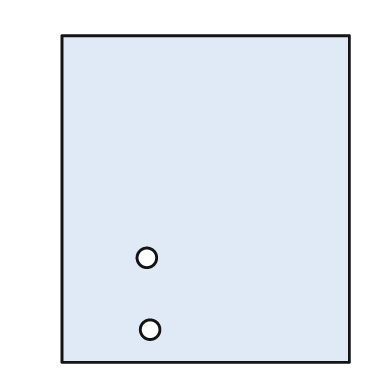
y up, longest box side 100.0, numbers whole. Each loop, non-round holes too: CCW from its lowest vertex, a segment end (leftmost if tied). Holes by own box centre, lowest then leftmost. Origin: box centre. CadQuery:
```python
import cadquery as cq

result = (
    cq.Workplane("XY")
    .moveTo(-44.0, -50.0)
    .lineTo(44.0, -50.0)
    .lineTo(44.0, 50.0)
    .lineTo(-44.0, 50.0)
    .close()
    .moveTo(-17.0, -40.0)
    .circle(3.0)
    .moveTo(-18.0, -18.0)
    .circle(3.0)
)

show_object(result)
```